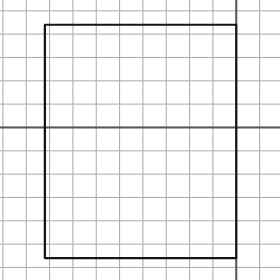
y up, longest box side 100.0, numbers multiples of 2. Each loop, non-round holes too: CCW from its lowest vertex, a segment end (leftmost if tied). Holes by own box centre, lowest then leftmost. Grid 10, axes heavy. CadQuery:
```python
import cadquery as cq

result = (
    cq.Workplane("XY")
    .moveTo(-82.0, -56.0)
    .lineTo(0.0, -56.0)
    .lineTo(0.0, 44.0)
    .lineTo(-82.0, 44.0)
    .close()
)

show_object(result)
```